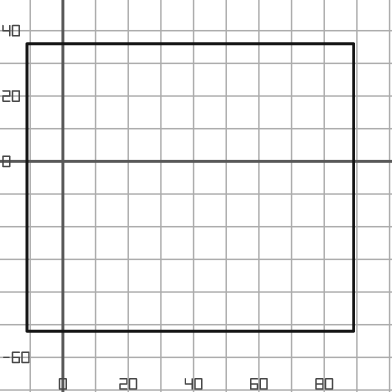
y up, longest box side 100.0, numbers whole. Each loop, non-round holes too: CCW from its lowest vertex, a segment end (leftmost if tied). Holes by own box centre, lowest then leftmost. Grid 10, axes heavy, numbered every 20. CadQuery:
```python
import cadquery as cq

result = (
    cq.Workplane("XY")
    .moveTo(-11.0, -52.0)
    .lineTo(89.0, -52.0)
    .lineTo(89.0, 36.0)
    .lineTo(-11.0, 36.0)
    .close()
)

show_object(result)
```